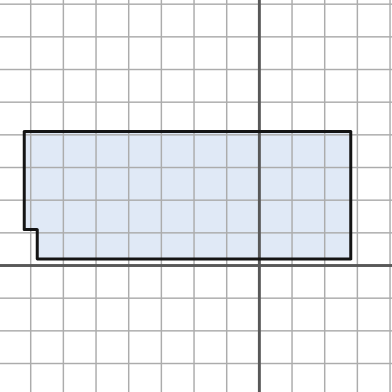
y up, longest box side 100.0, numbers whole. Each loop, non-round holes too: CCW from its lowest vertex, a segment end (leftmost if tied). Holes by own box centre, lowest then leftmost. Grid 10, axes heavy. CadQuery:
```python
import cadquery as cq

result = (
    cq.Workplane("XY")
    .moveTo(-68.0, 2.0)
    .lineTo(28.0, 2.0)
    .lineTo(28.0, 41.0)
    .lineTo(-72.0, 41.0)
    .lineTo(-72.0, 11.0)
    .lineTo(-68.0, 11.0)
    .close()
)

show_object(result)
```